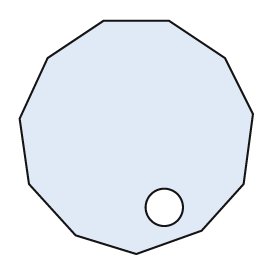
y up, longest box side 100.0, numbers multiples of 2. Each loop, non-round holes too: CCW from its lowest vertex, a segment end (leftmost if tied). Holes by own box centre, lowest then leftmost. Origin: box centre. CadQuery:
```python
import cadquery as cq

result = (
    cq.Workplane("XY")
    .moveTo(0.0, -50.0)
    .lineTo(28.0, -40.0)
    .lineTo(46.0, -20.0)
    .lineTo(50.0, 10.0)
    .lineTo(38.0, 34.0)
    .lineTo(14.0, 50.0)
    .lineTo(-14.0, 50.0)
    .lineTo(-38.0, 34.0)
    .lineTo(-50.0, 8.0)
    .lineTo(-46.0, -20.0)
    .lineTo(-26.0, -42.0)
    .close()
    .moveTo(12.0, -30.0)
    .circle(8.0)
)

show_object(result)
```